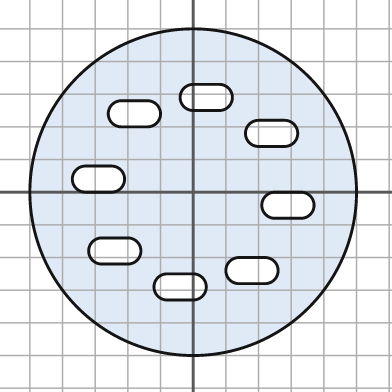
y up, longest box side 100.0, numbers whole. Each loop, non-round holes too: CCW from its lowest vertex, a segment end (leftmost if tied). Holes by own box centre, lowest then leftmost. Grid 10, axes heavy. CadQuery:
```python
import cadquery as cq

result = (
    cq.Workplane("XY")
    .moveTo(0.0, 0.0)
    .circle(50.0)
    .moveTo(-8.0, -33.0)
    .lineTo(0.0, -33.0)
    .threePointArc((4.0, -29.0), (0.0, -25.0))
    .lineTo(-8.0, -25.0)
    .threePointArc((-12.0, -29.0), (-8.0, -33.0))
    .close()
    .moveTo(14.0, -28.0)
    .lineTo(22.0, -28.0)
    .threePointArc((26.0, -24.0), (22.0, -20.0))
    .lineTo(14.0, -20.0)
    .threePointArc((10.0, -24.0), (14.0, -28.0))
    .close()
    .moveTo(-28.0, -22.0)
    .lineTo(-20.0, -22.0)
    .threePointArc((-16.0, -18.0), (-20.0, -14.0))
    .lineTo(-28.0, -14.0)
    .threePointArc((-32.0, -18.0), (-28.0, -22.0))
    .close()
    .moveTo(25.0, -8.0)
    .lineTo(33.0, -8.0)
    .threePointArc((37.0, -4.0), (33.0, 0.0))
    .lineTo(25.0, 0.0)
    .threePointArc((21.0, -4.0), (25.0, -8.0))
    .close()
    .moveTo(-33.0, 0.0)
    .lineTo(-25.0, 0.0)
    .threePointArc((-21.0, 4.0), (-25.0, 8.0))
    .lineTo(-33.0, 8.0)
    .threePointArc((-37.0, 4.0), (-33.0, 0.0))
    .close()
    .moveTo(20.0, 14.0)
    .lineTo(28.0, 14.0)
    .threePointArc((32.0, 18.0), (28.0, 22.0))
    .lineTo(20.0, 22.0)
    .threePointArc((16.0, 18.0), (20.0, 14.0))
    .close()
    .moveTo(-22.0, 20.0)
    .lineTo(-14.0, 20.0)
    .threePointArc((-10.0, 24.0), (-14.0, 28.0))
    .lineTo(-22.0, 28.0)
    .threePointArc((-26.0, 24.0), (-22.0, 20.0))
    .close()
    .moveTo(0.0, 25.0)
    .lineTo(8.0, 25.0)
    .threePointArc((12.0, 29.0), (8.0, 33.0))
    .lineTo(0.0, 33.0)
    .threePointArc((-4.0, 29.0), (0.0, 25.0))
    .close()
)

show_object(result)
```